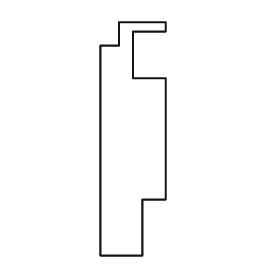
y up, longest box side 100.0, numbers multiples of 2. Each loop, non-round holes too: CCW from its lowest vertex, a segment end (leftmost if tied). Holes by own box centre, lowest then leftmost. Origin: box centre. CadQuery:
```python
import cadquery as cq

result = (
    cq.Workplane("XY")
    .moveTo(-14.0, -50.0)
    .lineTo(4.0, -50.0)
    .lineTo(4.0, -26.0)
    .lineTo(14.0, -26.0)
    .lineTo(14.0, 26.0)
    .lineTo(0.0, 26.0)
    .lineTo(0.0, 46.0)
    .lineTo(14.0, 46.0)
    .lineTo(14.0, 50.0)
    .lineTo(-6.0, 50.0)
    .lineTo(-6.0, 40.0)
    .lineTo(-14.0, 40.0)
    .close()
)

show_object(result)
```